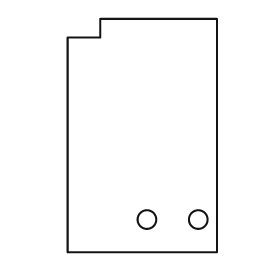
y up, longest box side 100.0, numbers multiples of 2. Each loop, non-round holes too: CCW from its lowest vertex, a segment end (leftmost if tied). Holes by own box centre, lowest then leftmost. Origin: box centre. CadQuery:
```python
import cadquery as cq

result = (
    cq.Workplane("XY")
    .moveTo(-32.0, -50.0)
    .lineTo(32.0, -50.0)
    .lineTo(32.0, 50.0)
    .lineTo(-18.0, 50.0)
    .lineTo(-18.0, 42.0)
    .lineTo(-32.0, 42.0)
    .close()
    .moveTo(2.0, -36.0)
    .circle(4.0)
    .moveTo(24.0, -36.0)
    .circle(4.0)
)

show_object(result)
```